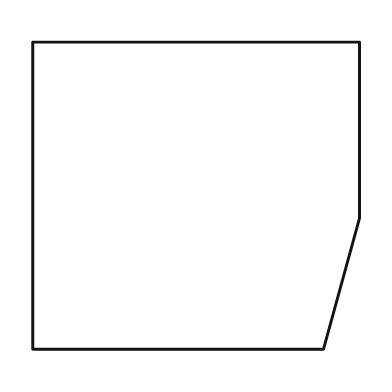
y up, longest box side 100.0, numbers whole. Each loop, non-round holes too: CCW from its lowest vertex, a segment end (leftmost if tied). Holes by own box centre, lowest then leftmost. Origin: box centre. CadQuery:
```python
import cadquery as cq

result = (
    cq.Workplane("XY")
    .moveTo(-50.0, -47.0)
    .lineTo(39.0, -47.0)
    .lineTo(50.0, -7.0)
    .lineTo(50.0, 47.0)
    .lineTo(-50.0, 47.0)
    .close()
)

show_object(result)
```